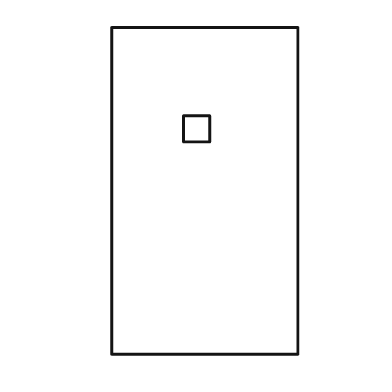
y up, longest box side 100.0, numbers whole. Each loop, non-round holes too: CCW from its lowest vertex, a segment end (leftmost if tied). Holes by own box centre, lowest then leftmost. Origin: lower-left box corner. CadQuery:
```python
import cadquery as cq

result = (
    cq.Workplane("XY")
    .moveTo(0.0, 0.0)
    .lineTo(57.0, 0.0)
    .lineTo(57.0, 100.0)
    .lineTo(0.0, 100.0)
    .close()
    .moveTo(22.0, 65.0)
    .lineTo(30.0, 65.0)
    .lineTo(30.0, 73.0)
    .lineTo(22.0, 73.0)
    .close()
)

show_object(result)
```